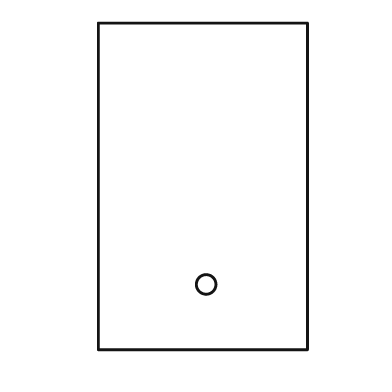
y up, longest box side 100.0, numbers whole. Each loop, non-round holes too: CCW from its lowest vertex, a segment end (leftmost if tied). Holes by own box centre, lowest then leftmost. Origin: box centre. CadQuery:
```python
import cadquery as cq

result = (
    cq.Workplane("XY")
    .moveTo(-32.0, -50.0)
    .lineTo(32.0, -50.0)
    .lineTo(32.0, 50.0)
    .lineTo(-32.0, 50.0)
    .close()
    .moveTo(1.0, -30.0)
    .circle(3.0)
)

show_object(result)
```